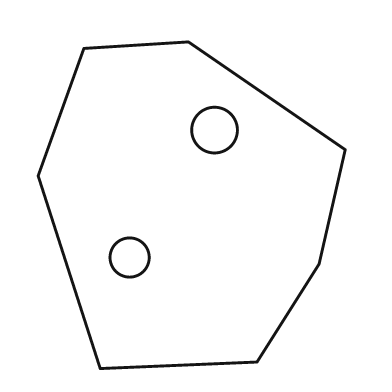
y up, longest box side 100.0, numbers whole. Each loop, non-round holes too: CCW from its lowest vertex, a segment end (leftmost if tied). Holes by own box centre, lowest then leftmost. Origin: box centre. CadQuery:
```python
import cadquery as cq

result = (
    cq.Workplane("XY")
    .moveTo(-28.0, -50.0)
    .lineTo(20.0, -48.0)
    .lineTo(39.0, -18.0)
    .lineTo(47.0, 17.0)
    .lineTo(-1.0, 50.0)
    .lineTo(-33.0, 48.0)
    .lineTo(-47.0, 9.0)
    .close()
    .moveTo(-19.0, -16.0)
    .circle(6.0)
    .moveTo(7.0, 23.0)
    .circle(7.0)
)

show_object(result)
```